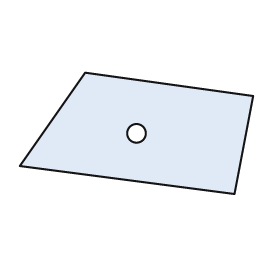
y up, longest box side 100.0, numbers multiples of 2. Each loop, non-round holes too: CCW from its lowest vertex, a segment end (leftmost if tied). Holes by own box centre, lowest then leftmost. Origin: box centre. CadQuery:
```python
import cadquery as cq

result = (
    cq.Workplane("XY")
    .moveTo(42.0, -26.0)
    .lineTo(50.0, 16.0)
    .lineTo(-22.0, 26.0)
    .lineTo(-50.0, -14.0)
    .close()
    .moveTo(0.0, 0.0)
    .circle(4.0)
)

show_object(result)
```